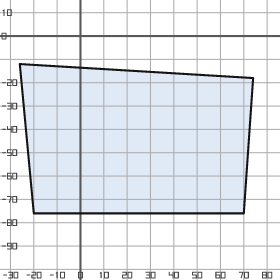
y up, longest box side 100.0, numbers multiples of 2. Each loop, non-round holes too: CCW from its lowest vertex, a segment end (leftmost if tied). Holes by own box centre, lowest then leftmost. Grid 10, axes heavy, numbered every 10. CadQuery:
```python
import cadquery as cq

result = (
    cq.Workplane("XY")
    .moveTo(-20.0, -76.0)
    .lineTo(70.0, -76.0)
    .lineTo(74.0, -18.0)
    .lineTo(-26.0, -12.0)
    .close()
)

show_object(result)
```